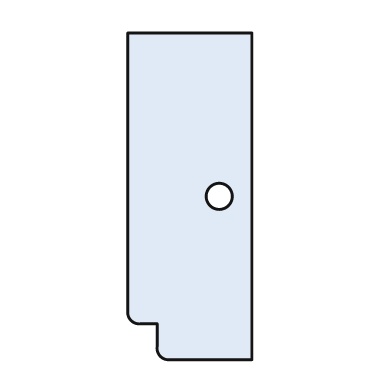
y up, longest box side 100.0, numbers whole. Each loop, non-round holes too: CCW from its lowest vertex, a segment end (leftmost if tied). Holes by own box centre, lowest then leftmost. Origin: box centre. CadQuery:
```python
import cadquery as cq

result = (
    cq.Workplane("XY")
    .moveTo(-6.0, -50.0)
    .lineTo(19.0, -50.0)
    .lineTo(19.0, 50.0)
    .lineTo(-19.0, 50.0)
    .lineTo(-19.0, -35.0)
    .threePointArc((-18.0, -38.0), (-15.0, -39.0))
    .lineTo(-10.0, -39.0)
    .lineTo(-10.0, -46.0)
    .threePointArc((-9.0, -49.0), (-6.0, -50.0))
    .close()
    .moveTo(9.0, 0.0)
    .circle(4.0)
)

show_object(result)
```